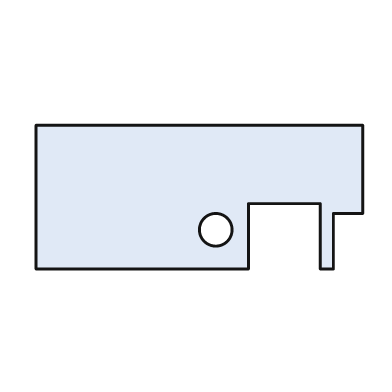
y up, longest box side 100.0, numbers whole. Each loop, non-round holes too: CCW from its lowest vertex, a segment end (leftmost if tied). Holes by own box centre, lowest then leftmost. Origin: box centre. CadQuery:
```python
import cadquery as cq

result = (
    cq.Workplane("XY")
    .moveTo(-50.0, -22.0)
    .lineTo(15.0, -22.0)
    .lineTo(15.0, -2.0)
    .lineTo(37.0, -2.0)
    .lineTo(37.0, -22.0)
    .lineTo(41.0, -22.0)
    .lineTo(41.0, -5.0)
    .lineTo(50.0, -5.0)
    .lineTo(50.0, 22.0)
    .lineTo(-50.0, 22.0)
    .close()
    .moveTo(5.0, -10.0)
    .circle(5.0)
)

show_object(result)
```